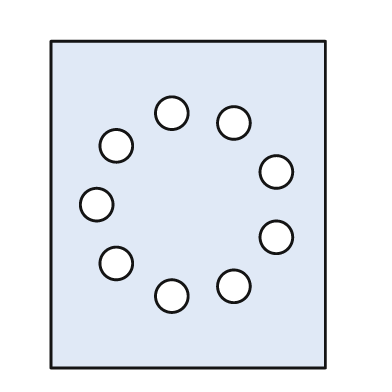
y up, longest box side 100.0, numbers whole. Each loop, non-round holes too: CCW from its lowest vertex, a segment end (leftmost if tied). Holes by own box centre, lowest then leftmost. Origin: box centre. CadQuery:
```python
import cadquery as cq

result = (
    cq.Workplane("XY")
    .moveTo(-42.0, -50.0)
    .lineTo(42.0, -50.0)
    .lineTo(42.0, 50.0)
    .lineTo(-42.0, 50.0)
    .close()
    .moveTo(-5.0, -28.0)
    .circle(5.0)
    .moveTo(14.0, -25.0)
    .circle(5.0)
    .moveTo(-22.0, -18.0)
    .circle(5.0)
    .moveTo(27.0, -10.0)
    .circle(5.0)
    .moveTo(-28.0, 0.0)
    .circle(5.0)
    .moveTo(27.0, 10.0)
    .circle(5.0)
    .moveTo(-22.0, 18.0)
    .circle(5.0)
    .moveTo(14.0, 25.0)
    .circle(5.0)
    .moveTo(-5.0, 28.0)
    .circle(5.0)
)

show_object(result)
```